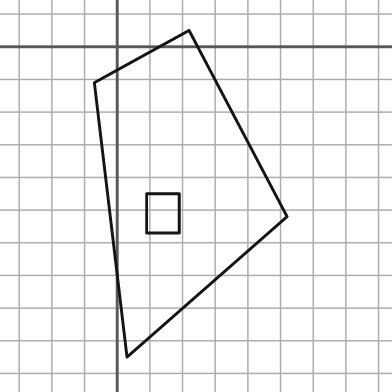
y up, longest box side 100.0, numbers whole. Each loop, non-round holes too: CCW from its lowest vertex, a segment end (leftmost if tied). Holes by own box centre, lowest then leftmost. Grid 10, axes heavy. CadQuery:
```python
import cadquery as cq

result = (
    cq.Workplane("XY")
    .moveTo(3.0, -95.0)
    .lineTo(52.0, -52.0)
    .lineTo(22.0, 5.0)
    .lineTo(-7.0, -11.0)
    .close()
    .moveTo(9.0, -57.0)
    .lineTo(19.0, -57.0)
    .lineTo(19.0, -45.0)
    .lineTo(9.0, -45.0)
    .close()
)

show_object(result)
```